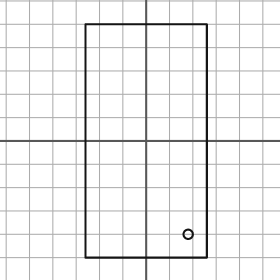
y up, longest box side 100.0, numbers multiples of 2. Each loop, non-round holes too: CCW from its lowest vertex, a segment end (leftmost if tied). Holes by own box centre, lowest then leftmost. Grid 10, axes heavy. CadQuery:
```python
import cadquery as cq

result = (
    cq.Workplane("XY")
    .moveTo(-26.0, -50.0)
    .lineTo(26.0, -50.0)
    .lineTo(26.0, 50.0)
    .lineTo(-26.0, 50.0)
    .close()
    .moveTo(18.0, -40.0)
    .circle(2.0)
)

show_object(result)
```